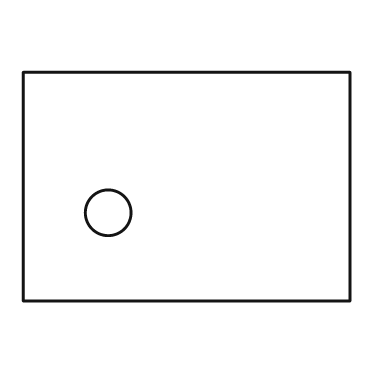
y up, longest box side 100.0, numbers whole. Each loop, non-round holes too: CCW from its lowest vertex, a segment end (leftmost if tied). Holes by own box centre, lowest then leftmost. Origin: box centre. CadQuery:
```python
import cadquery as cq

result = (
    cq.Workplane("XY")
    .moveTo(-50.0, -35.0)
    .lineTo(50.0, -35.0)
    .lineTo(50.0, 35.0)
    .lineTo(-50.0, 35.0)
    .close()
    .moveTo(-24.0, -8.0)
    .circle(7.0)
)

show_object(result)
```